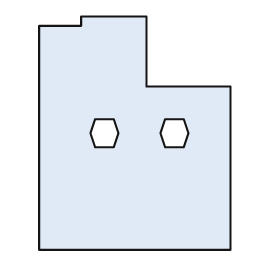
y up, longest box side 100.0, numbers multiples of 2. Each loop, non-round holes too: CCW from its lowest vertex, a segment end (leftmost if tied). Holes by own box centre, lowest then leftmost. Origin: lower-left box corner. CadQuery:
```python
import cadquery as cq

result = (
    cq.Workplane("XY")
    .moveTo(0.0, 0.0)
    .lineTo(82.0, 0.0)
    .lineTo(82.0, 70.0)
    .lineTo(46.0, 70.0)
    .lineTo(46.0, 100.0)
    .lineTo(18.0, 100.0)
    .lineTo(18.0, 96.0)
    .lineTo(0.0, 96.0)
    .close()
    .moveTo(24.0, 44.0)
    .lineTo(32.0, 44.0)
    .lineTo(34.0, 50.0)
    .lineTo(32.0, 56.0)
    .lineTo(24.0, 56.0)
    .lineTo(22.0, 50.0)
    .close()
    .moveTo(54.0, 44.0)
    .lineTo(62.0, 44.0)
    .lineTo(64.0, 50.0)
    .lineTo(62.0, 56.0)
    .lineTo(54.0, 56.0)
    .lineTo(52.0, 50.0)
    .close()
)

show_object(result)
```